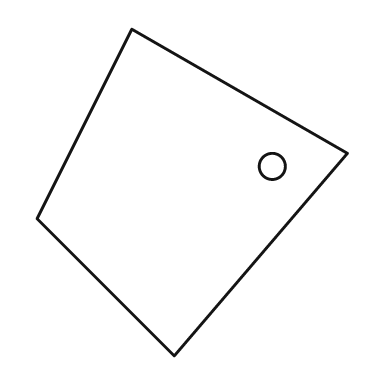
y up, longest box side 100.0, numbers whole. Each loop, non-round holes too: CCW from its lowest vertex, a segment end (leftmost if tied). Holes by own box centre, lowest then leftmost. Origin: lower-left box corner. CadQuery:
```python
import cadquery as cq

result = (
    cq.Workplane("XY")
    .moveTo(42.0, 0.0)
    .lineTo(95.0, 62.0)
    .lineTo(29.0, 100.0)
    .lineTo(0.0, 42.0)
    .close()
    .moveTo(72.0, 58.0)
    .circle(4.0)
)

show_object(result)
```